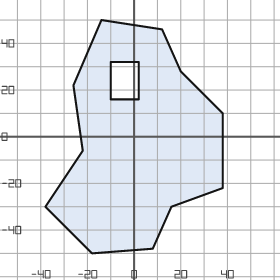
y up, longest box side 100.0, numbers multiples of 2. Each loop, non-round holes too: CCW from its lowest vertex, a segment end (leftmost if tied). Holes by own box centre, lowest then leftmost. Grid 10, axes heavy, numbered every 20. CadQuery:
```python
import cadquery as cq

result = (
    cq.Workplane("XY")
    .moveTo(-18.0, -50.0)
    .lineTo(8.0, -48.0)
    .lineTo(16.0, -30.0)
    .lineTo(38.0, -22.0)
    .lineTo(38.0, 10.0)
    .lineTo(20.0, 28.0)
    .lineTo(12.0, 46.0)
    .lineTo(-14.0, 50.0)
    .lineTo(-26.0, 22.0)
    .lineTo(-22.0, -6.0)
    .lineTo(-38.0, -30.0)
    .close()
    .moveTo(-10.0, 16.0)
    .lineTo(2.0, 16.0)
    .lineTo(2.0, 32.0)
    .lineTo(-10.0, 32.0)
    .close()
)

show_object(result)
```